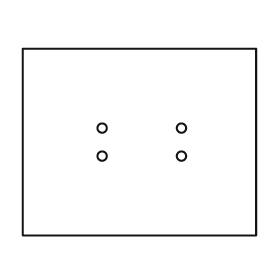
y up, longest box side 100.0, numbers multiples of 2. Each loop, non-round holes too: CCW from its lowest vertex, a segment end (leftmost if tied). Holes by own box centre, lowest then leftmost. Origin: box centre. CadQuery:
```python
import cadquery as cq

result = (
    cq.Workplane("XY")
    .moveTo(-50.0, -40.0)
    .lineTo(50.0, -40.0)
    .lineTo(50.0, 40.0)
    .lineTo(-50.0, 40.0)
    .close()
    .moveTo(-16.0, -6.0)
    .circle(2.0)
    .moveTo(18.0, -6.0)
    .circle(2.0)
    .moveTo(-16.0, 6.0)
    .circle(2.0)
    .moveTo(18.0, 6.0)
    .circle(2.0)
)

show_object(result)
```